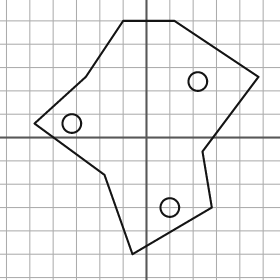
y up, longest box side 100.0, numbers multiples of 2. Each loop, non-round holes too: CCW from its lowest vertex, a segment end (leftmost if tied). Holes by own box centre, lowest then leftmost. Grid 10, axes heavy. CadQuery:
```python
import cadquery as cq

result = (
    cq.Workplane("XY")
    .moveTo(-6.0, -50.0)
    .lineTo(28.0, -30.0)
    .lineTo(24.0, -6.0)
    .lineTo(48.0, 26.0)
    .lineTo(12.0, 50.0)
    .lineTo(-10.0, 50.0)
    .lineTo(-26.0, 26.0)
    .lineTo(-48.0, 6.0)
    .lineTo(-18.0, -16.0)
    .close()
    .moveTo(10.0, -30.0)
    .circle(4.0)
    .moveTo(-32.0, 6.0)
    .circle(4.0)
    .moveTo(22.0, 24.0)
    .circle(4.0)
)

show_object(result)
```